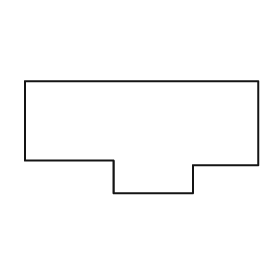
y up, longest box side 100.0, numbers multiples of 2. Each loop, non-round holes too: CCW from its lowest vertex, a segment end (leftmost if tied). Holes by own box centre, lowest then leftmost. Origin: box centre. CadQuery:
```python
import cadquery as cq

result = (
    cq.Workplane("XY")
    .moveTo(-12.0, -24.0)
    .lineTo(22.0, -24.0)
    .lineTo(22.0, -12.0)
    .lineTo(50.0, -12.0)
    .lineTo(50.0, 24.0)
    .lineTo(-50.0, 24.0)
    .lineTo(-50.0, -10.0)
    .lineTo(-12.0, -10.0)
    .close()
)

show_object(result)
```